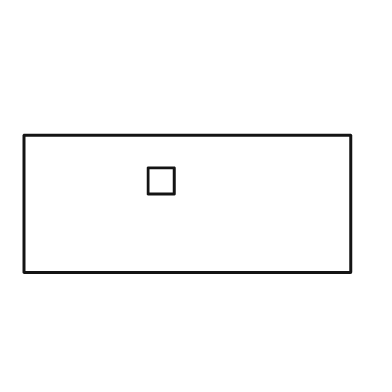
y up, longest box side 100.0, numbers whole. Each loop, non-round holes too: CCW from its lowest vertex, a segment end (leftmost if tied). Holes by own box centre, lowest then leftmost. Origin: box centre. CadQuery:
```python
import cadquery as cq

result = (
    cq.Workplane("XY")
    .moveTo(-50.0, -21.0)
    .lineTo(50.0, -21.0)
    .lineTo(50.0, 21.0)
    .lineTo(-50.0, 21.0)
    .close()
    .moveTo(-12.0, 3.0)
    .lineTo(-4.0, 3.0)
    .lineTo(-4.0, 11.0)
    .lineTo(-12.0, 11.0)
    .close()
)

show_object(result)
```